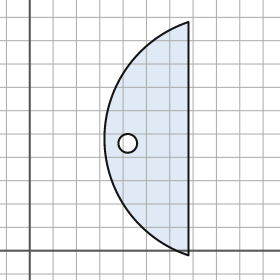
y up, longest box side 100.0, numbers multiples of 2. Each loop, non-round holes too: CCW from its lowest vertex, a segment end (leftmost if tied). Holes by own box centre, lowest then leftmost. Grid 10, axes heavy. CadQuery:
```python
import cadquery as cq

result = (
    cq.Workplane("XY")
    .moveTo(68.0, -2.0)
    .lineTo(68.0, 98.0)
    .threePointArc((32.0, 48.0), (68.0, -2.0))
    .close()
    .moveTo(42.0, 46.0)
    .circle(4.0)
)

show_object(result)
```